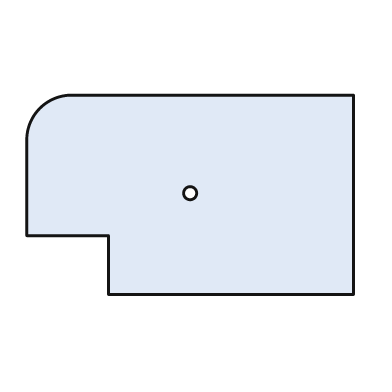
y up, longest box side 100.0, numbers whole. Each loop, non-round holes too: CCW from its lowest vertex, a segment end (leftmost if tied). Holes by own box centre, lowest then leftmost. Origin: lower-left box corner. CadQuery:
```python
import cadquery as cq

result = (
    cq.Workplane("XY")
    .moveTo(25.0, 0.0)
    .lineTo(100.0, 0.0)
    .lineTo(100.0, 61.0)
    .lineTo(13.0, 61.0)
    .threePointArc((4.0, 57.0), (0.0, 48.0))
    .lineTo(0.0, 18.0)
    .lineTo(25.0, 18.0)
    .close()
    .moveTo(50.0, 31.0)
    .circle(2.0)
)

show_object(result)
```